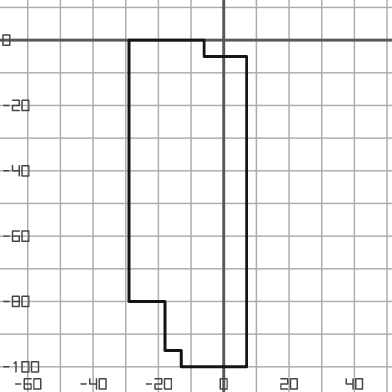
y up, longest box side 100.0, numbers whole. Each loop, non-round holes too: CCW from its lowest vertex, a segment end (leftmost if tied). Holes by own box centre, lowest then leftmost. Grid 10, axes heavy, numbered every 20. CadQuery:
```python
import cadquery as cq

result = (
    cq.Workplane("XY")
    .moveTo(-13.0, -100.0)
    .lineTo(7.0, -100.0)
    .lineTo(7.0, -5.0)
    .lineTo(-6.0, -5.0)
    .lineTo(-6.0, 0.0)
    .lineTo(-29.0, 0.0)
    .lineTo(-29.0, -80.0)
    .lineTo(-18.0, -80.0)
    .lineTo(-18.0, -95.0)
    .lineTo(-13.0, -95.0)
    .close()
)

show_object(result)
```